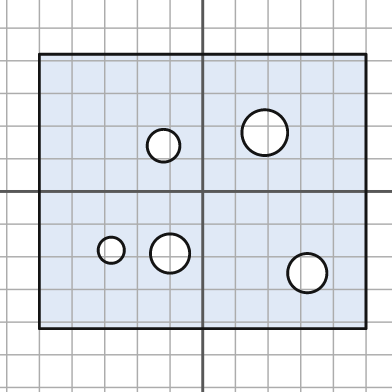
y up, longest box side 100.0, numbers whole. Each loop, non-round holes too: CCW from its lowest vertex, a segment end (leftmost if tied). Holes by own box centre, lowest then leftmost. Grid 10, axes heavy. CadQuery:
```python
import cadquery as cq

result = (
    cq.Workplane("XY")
    .moveTo(-50.0, -42.0)
    .lineTo(50.0, -42.0)
    .lineTo(50.0, 42.0)
    .lineTo(-50.0, 42.0)
    .close()
    .moveTo(32.0, -25.0)
    .circle(6.0)
    .moveTo(-10.0, -19.0)
    .circle(6.0)
    .moveTo(-28.0, -18.0)
    .circle(4.0)
    .moveTo(-12.0, 14.0)
    .circle(5.0)
    .moveTo(19.0, 18.0)
    .circle(7.0)
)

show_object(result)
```